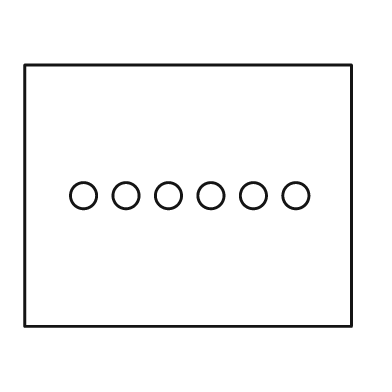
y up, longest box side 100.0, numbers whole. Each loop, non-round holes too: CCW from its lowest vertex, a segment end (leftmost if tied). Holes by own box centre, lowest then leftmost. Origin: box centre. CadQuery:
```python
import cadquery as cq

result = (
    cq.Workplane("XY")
    .moveTo(-50.0, -40.0)
    .lineTo(50.0, -40.0)
    .lineTo(50.0, 40.0)
    .lineTo(-50.0, 40.0)
    .close()
    .moveTo(-32.0, 0.0)
    .circle(4.0)
    .moveTo(-19.0, 0.0)
    .circle(4.0)
    .moveTo(-6.0, 0.0)
    .circle(4.0)
    .moveTo(7.0, 0.0)
    .circle(4.0)
    .moveTo(20.0, 0.0)
    .circle(4.0)
    .moveTo(33.0, 0.0)
    .circle(4.0)
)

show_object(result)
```